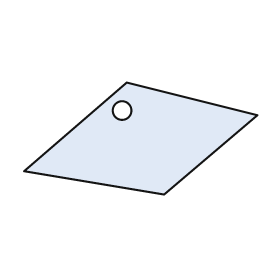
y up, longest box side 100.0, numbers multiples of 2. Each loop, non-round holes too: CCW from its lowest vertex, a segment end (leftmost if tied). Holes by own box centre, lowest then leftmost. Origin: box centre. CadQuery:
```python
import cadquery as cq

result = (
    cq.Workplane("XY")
    .moveTo(10.0, -24.0)
    .lineTo(50.0, 10.0)
    .lineTo(-6.0, 24.0)
    .lineTo(-50.0, -14.0)
    .close()
    .moveTo(-8.0, 12.0)
    .circle(4.0)
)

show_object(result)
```